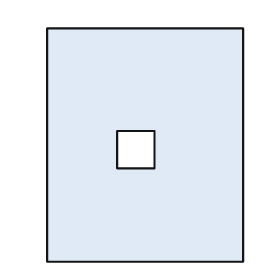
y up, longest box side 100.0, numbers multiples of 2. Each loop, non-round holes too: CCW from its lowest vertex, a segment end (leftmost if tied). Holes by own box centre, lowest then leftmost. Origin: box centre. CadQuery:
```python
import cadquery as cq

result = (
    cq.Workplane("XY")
    .moveTo(-42.0, -50.0)
    .lineTo(42.0, -50.0)
    .lineTo(42.0, 50.0)
    .lineTo(-42.0, 50.0)
    .close()
    .moveTo(-12.0, -10.0)
    .lineTo(4.0, -10.0)
    .lineTo(4.0, 6.0)
    .lineTo(-12.0, 6.0)
    .close()
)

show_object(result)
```